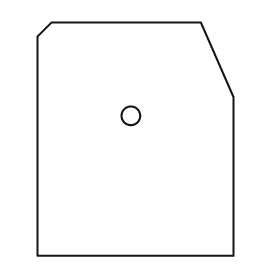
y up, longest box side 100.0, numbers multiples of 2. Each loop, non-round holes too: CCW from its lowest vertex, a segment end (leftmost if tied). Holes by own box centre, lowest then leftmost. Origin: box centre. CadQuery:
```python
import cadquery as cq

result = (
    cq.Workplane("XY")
    .moveTo(-42.0, -50.0)
    .lineTo(42.0, -50.0)
    .lineTo(42.0, 18.0)
    .lineTo(28.0, 50.0)
    .lineTo(-36.0, 50.0)
    .lineTo(-42.0, 44.0)
    .close()
    .moveTo(-2.0, 10.0)
    .circle(4.0)
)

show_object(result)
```